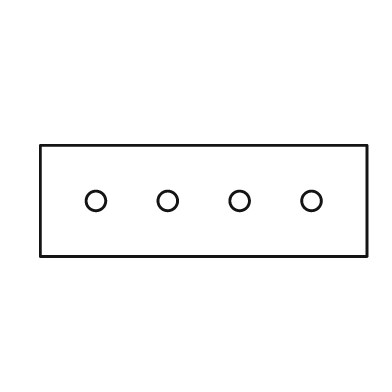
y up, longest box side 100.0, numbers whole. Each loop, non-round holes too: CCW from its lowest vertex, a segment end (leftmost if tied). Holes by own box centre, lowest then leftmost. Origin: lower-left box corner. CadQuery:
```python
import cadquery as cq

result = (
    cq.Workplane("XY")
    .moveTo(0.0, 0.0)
    .lineTo(100.0, 0.0)
    .lineTo(100.0, 34.0)
    .lineTo(0.0, 34.0)
    .close()
    .moveTo(17.0, 17.0)
    .circle(3.0)
    .moveTo(39.0, 17.0)
    .circle(3.0)
    .moveTo(61.0, 17.0)
    .circle(3.0)
    .moveTo(83.0, 17.0)
    .circle(3.0)
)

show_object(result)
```